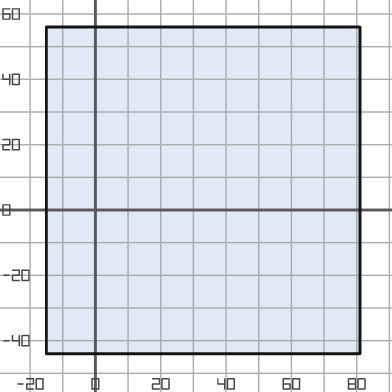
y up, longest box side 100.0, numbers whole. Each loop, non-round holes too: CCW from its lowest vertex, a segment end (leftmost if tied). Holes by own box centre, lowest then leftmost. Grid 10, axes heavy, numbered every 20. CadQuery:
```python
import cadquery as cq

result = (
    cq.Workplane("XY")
    .moveTo(-15.0, -44.0)
    .lineTo(81.0, -44.0)
    .lineTo(81.0, 56.0)
    .lineTo(-15.0, 56.0)
    .close()
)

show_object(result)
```